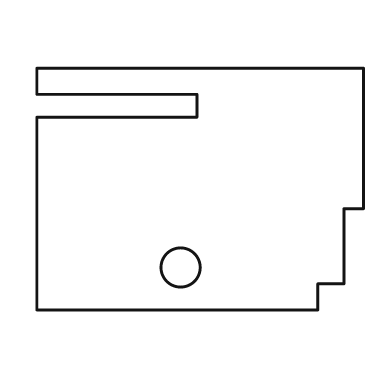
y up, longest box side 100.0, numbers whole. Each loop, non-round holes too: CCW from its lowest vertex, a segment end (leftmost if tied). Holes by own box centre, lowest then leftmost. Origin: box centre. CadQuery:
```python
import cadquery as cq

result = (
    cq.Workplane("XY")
    .moveTo(-50.0, -37.0)
    .lineTo(36.0, -37.0)
    .lineTo(36.0, -29.0)
    .lineTo(44.0, -29.0)
    .lineTo(44.0, -6.0)
    .lineTo(50.0, -6.0)
    .lineTo(50.0, 37.0)
    .lineTo(-50.0, 37.0)
    .lineTo(-50.0, 29.0)
    .lineTo(-1.0, 29.0)
    .lineTo(-1.0, 22.0)
    .lineTo(-50.0, 22.0)
    .close()
    .moveTo(-6.0, -24.0)
    .circle(6.0)
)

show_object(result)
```